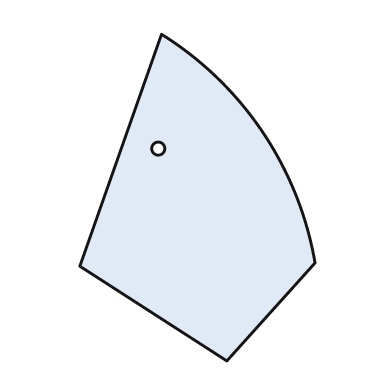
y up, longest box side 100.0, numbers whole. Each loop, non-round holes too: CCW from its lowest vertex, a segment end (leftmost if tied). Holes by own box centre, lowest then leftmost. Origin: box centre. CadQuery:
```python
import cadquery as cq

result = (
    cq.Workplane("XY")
    .moveTo(9.0, -50.0)
    .lineTo(36.0, -20.0)
    .threePointArc((20.0, 20.0), (-11.0, 50.0))
    .lineTo(-36.0, -21.0)
    .close()
    .moveTo(-12.0, 15.0)
    .circle(2.0)
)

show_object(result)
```